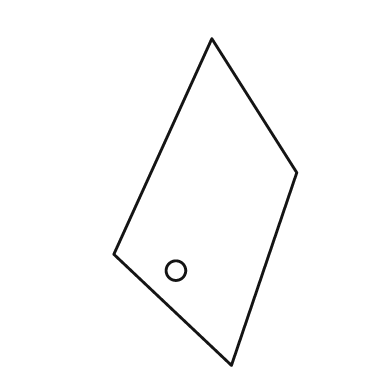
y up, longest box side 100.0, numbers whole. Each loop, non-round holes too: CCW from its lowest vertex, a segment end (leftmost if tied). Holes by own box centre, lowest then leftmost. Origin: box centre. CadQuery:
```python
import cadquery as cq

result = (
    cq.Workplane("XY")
    .moveTo(8.0, -50.0)
    .lineTo(28.0, 9.0)
    .lineTo(2.0, 50.0)
    .lineTo(-28.0, -16.0)
    .close()
    .moveTo(-9.0, -21.0)
    .circle(3.0)
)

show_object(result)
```